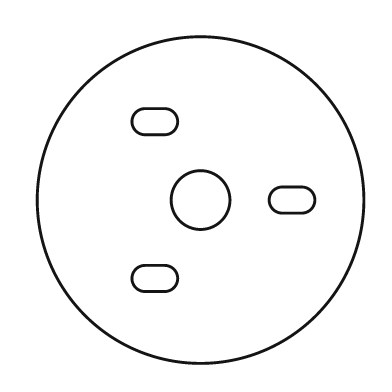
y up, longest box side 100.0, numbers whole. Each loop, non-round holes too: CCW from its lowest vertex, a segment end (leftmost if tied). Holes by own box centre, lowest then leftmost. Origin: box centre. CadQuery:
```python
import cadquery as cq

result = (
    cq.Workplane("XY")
    .moveTo(0.0, 0.0)
    .circle(50.0)
    .moveTo(-17.0, -28.0)
    .lineTo(-11.0, -28.0)
    .threePointArc((-7.0, -24.0), (-11.0, -20.0))
    .lineTo(-17.0, -20.0)
    .threePointArc((-21.0, -24.0), (-17.0, -28.0))
    .close()
    .moveTo(0.0, 0.0)
    .circle(9.0)
    .moveTo(25.0, -4.0)
    .lineTo(31.0, -4.0)
    .threePointArc((35.0, 0.0), (31.0, 4.0))
    .lineTo(25.0, 4.0)
    .threePointArc((21.0, 0.0), (25.0, -4.0))
    .close()
    .moveTo(-17.0, 20.0)
    .lineTo(-11.0, 20.0)
    .threePointArc((-7.0, 24.0), (-11.0, 28.0))
    .lineTo(-17.0, 28.0)
    .threePointArc((-21.0, 24.0), (-17.0, 20.0))
    .close()
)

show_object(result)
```